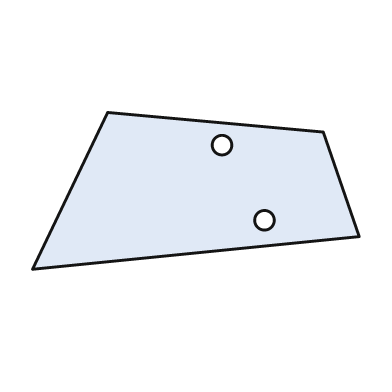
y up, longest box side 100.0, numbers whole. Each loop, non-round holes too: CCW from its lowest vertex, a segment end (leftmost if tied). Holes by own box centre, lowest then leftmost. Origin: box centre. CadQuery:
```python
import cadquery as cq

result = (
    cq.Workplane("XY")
    .moveTo(-50.0, -24.0)
    .lineTo(50.0, -14.0)
    .lineTo(39.0, 18.0)
    .lineTo(-27.0, 24.0)
    .close()
    .moveTo(21.0, -9.0)
    .circle(3.0)
    .moveTo(8.0, 14.0)
    .circle(3.0)
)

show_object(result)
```